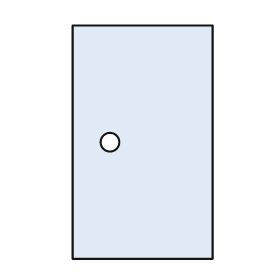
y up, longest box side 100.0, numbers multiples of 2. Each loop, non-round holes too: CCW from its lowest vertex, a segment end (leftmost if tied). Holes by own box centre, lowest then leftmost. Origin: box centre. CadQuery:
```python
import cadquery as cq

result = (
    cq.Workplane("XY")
    .moveTo(-30.0, -50.0)
    .lineTo(30.0, -50.0)
    .lineTo(30.0, 50.0)
    .lineTo(-30.0, 50.0)
    .close()
    .moveTo(-14.0, 0.0)
    .circle(4.0)
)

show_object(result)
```